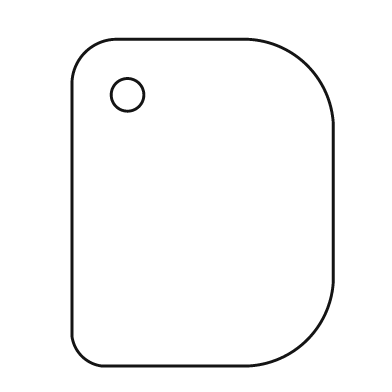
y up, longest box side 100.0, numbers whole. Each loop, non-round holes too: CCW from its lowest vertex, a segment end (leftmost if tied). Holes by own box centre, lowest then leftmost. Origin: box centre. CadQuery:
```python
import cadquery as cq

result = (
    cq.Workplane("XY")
    .moveTo(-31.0, -50.0)
    .lineTo(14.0, -50.0)
    .threePointArc((32.0, -42.0), (40.0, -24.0))
    .lineTo(40.0, 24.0)
    .threePointArc((32.0, 42.0), (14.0, 50.0))
    .lineTo(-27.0, 50.0)
    .threePointArc((-36.0, 46.0), (-40.0, 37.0))
    .lineTo(-40.0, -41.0)
    .threePointArc((-37.0, -47.0), (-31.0, -50.0))
    .close()
    .moveTo(-23.0, 33.0)
    .circle(5.0)
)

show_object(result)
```